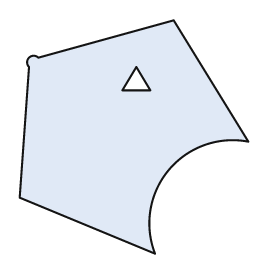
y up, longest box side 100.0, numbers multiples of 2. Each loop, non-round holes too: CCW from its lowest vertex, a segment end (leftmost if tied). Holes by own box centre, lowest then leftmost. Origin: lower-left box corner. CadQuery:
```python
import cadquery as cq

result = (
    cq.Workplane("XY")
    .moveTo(58.0, 0.0)
    .threePointArc((64.0, 36.0), (98.0, 48.0))
    .lineTo(66.0, 100.0)
    .lineTo(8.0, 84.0)
    .threePointArc((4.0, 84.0), (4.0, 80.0))
    .lineTo(0.0, 24.0)
    .close()
    .moveTo(44.0, 70.0)
    .lineTo(56.0, 70.0)
    .lineTo(50.0, 80.0)
    .close()
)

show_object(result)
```